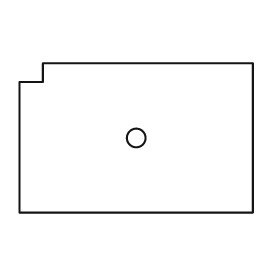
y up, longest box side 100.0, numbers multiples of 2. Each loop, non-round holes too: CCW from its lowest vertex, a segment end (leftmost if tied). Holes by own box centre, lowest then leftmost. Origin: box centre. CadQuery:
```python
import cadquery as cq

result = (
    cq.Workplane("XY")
    .moveTo(-50.0, -32.0)
    .lineTo(50.0, -32.0)
    .lineTo(50.0, 32.0)
    .lineTo(-40.0, 32.0)
    .lineTo(-40.0, 24.0)
    .lineTo(-50.0, 24.0)
    .close()
    .moveTo(0.0, 0.0)
    .circle(4.0)
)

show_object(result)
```